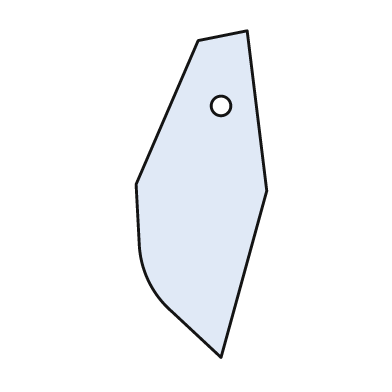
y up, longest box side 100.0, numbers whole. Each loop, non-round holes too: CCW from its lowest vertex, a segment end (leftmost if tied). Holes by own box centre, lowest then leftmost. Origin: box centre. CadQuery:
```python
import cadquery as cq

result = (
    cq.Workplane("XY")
    .moveTo(6.0, -50.0)
    .lineTo(20.0, 1.0)
    .lineTo(14.0, 50.0)
    .lineTo(-1.0, 47.0)
    .lineTo(-20.0, 3.0)
    .lineTo(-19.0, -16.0)
    .threePointArc((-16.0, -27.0), (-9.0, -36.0))
    .close()
    .moveTo(6.0, 27.0)
    .circle(3.0)
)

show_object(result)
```